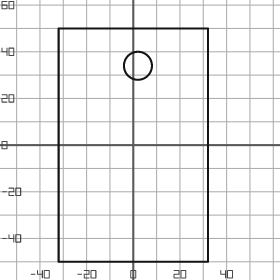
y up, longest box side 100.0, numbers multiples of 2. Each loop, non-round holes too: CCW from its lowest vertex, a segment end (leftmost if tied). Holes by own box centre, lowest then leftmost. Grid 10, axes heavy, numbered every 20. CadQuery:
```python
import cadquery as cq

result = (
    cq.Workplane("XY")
    .moveTo(-32.0, -50.0)
    .lineTo(32.0, -50.0)
    .lineTo(32.0, 50.0)
    .lineTo(-32.0, 50.0)
    .close()
    .moveTo(2.0, 34.0)
    .circle(6.0)
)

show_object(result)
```